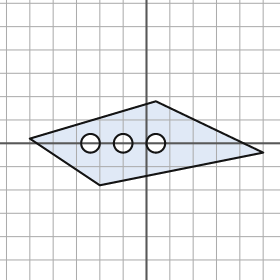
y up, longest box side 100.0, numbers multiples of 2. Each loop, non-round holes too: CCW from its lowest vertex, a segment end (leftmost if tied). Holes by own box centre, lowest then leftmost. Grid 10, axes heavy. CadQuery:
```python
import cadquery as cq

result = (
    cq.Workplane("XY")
    .moveTo(-20.0, -18.0)
    .lineTo(50.0, -4.0)
    .lineTo(4.0, 18.0)
    .lineTo(-50.0, 2.0)
    .close()
    .moveTo(-24.0, 0.0)
    .circle(4.0)
    .moveTo(-10.0, 0.0)
    .circle(4.0)
    .moveTo(4.0, 0.0)
    .circle(4.0)
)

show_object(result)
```